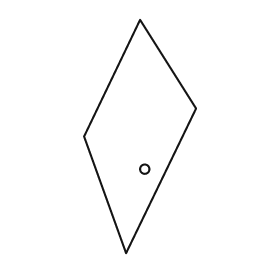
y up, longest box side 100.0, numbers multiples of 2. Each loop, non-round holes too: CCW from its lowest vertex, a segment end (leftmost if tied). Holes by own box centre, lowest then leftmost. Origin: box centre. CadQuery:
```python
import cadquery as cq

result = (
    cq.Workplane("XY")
    .moveTo(-6.0, -50.0)
    .lineTo(24.0, 12.0)
    .lineTo(0.0, 50.0)
    .lineTo(-24.0, 0.0)
    .close()
    .moveTo(2.0, -14.0)
    .circle(2.0)
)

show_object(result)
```